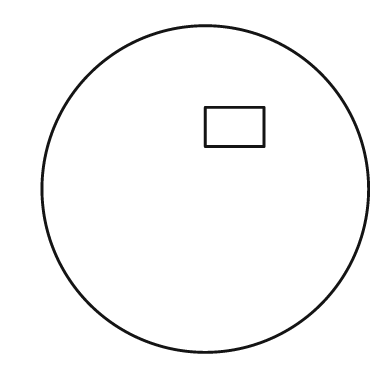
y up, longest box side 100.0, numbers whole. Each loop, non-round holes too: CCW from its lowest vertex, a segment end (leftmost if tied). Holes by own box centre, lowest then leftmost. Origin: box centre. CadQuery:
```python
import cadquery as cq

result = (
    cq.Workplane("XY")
    .moveTo(0.0, 0.0)
    .circle(50.0)
    .moveTo(0.0, 13.0)
    .lineTo(18.0, 13.0)
    .lineTo(18.0, 25.0)
    .lineTo(0.0, 25.0)
    .close()
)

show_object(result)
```